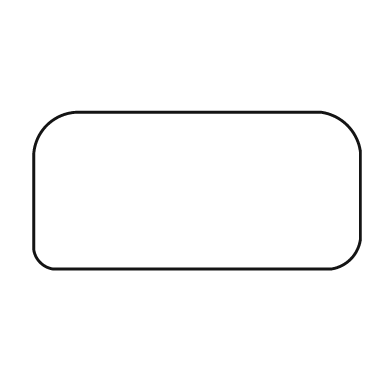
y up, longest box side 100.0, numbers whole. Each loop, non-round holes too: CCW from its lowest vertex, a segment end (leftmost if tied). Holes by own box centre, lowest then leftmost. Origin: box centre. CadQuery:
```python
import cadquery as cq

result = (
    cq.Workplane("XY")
    .moveTo(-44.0, -24.0)
    .lineTo(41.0, -24.0)
    .threePointArc((47.0, -21.0), (50.0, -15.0))
    .lineTo(50.0, 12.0)
    .threePointArc((46.0, 20.0), (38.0, 24.0))
    .lineTo(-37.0, 24.0)
    .threePointArc((-46.0, 20.0), (-50.0, 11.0))
    .lineTo(-50.0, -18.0)
    .threePointArc((-48.0, -22.0), (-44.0, -24.0))
    .close()
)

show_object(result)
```